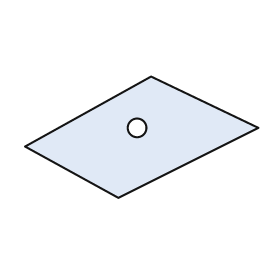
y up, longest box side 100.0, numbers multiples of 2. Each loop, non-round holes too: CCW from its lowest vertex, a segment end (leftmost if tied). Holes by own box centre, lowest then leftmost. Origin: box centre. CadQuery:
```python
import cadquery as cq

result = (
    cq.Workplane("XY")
    .moveTo(-10.0, -26.0)
    .lineTo(50.0, 4.0)
    .lineTo(4.0, 26.0)
    .lineTo(-50.0, -4.0)
    .close()
    .moveTo(-2.0, 4.0)
    .circle(4.0)
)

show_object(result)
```